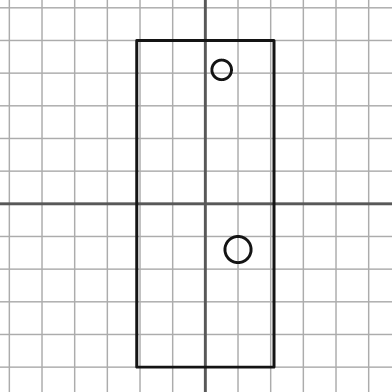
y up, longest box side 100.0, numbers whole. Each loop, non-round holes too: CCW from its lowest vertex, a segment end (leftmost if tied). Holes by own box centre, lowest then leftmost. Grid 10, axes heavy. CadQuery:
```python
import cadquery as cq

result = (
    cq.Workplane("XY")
    .moveTo(-21.0, -50.0)
    .lineTo(21.0, -50.0)
    .lineTo(21.0, 50.0)
    .lineTo(-21.0, 50.0)
    .close()
    .moveTo(10.0, -14.0)
    .circle(4.0)
    .moveTo(5.0, 41.0)
    .circle(3.0)
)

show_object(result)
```